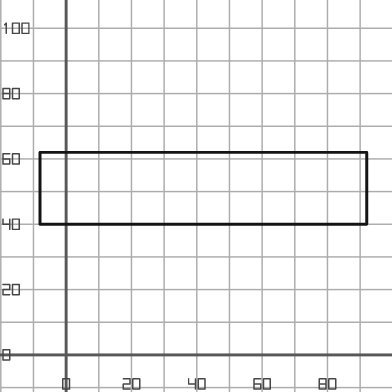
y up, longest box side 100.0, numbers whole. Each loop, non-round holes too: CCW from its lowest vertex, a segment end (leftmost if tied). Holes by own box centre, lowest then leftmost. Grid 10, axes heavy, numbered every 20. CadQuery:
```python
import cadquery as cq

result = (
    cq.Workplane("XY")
    .moveTo(-8.0, 40.0)
    .lineTo(92.0, 40.0)
    .lineTo(92.0, 62.0)
    .lineTo(-8.0, 62.0)
    .close()
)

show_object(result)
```